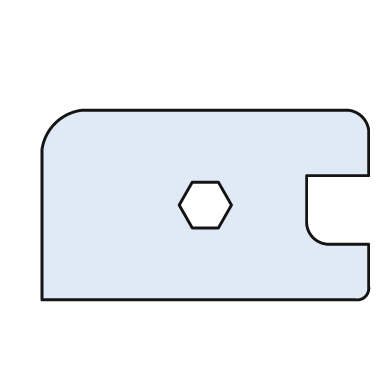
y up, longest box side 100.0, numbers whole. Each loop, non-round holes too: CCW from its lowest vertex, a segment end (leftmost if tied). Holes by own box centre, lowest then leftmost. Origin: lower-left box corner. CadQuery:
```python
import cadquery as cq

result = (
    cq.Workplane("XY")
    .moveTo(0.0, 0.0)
    .lineTo(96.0, 0.0)
    .threePointArc((99.0, 1.0), (100.0, 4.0))
    .lineTo(100.0, 17.0)
    .lineTo(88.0, 17.0)
    .threePointArc((83.0, 19.0), (81.0, 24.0))
    .lineTo(81.0, 38.0)
    .lineTo(100.0, 38.0)
    .lineTo(100.0, 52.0)
    .threePointArc((98.0, 56.0), (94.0, 58.0))
    .lineTo(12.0, 58.0)
    .threePointArc((4.0, 54.0), (0.0, 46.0))
    .close()
    .moveTo(46.0, 22.0)
    .lineTo(54.0, 22.0)
    .lineTo(58.0, 29.0)
    .lineTo(54.0, 36.0)
    .lineTo(46.0, 36.0)
    .lineTo(42.0, 29.0)
    .close()
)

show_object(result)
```